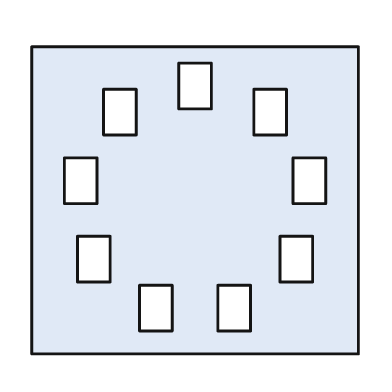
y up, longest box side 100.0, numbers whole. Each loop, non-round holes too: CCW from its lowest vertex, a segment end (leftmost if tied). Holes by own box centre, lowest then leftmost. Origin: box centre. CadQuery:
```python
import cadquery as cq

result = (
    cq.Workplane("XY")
    .moveTo(-50.0, -47.0)
    .lineTo(50.0, -47.0)
    .lineTo(50.0, 47.0)
    .lineTo(-50.0, 47.0)
    .close()
    .moveTo(-17.0, -40.0)
    .lineTo(-7.0, -40.0)
    .lineTo(-7.0, -26.0)
    .lineTo(-17.0, -26.0)
    .close()
    .moveTo(7.0, -40.0)
    .lineTo(17.0, -40.0)
    .lineTo(17.0, -26.0)
    .lineTo(7.0, -26.0)
    .close()
    .moveTo(-36.0, -25.0)
    .lineTo(-26.0, -25.0)
    .lineTo(-26.0, -11.0)
    .lineTo(-36.0, -11.0)
    .close()
    .moveTo(26.0, -25.0)
    .lineTo(36.0, -25.0)
    .lineTo(36.0, -11.0)
    .lineTo(26.0, -11.0)
    .close()
    .moveTo(-40.0, -1.0)
    .lineTo(-30.0, -1.0)
    .lineTo(-30.0, 13.0)
    .lineTo(-40.0, 13.0)
    .close()
    .moveTo(30.0, -1.0)
    .lineTo(40.0, -1.0)
    .lineTo(40.0, 13.0)
    .lineTo(30.0, 13.0)
    .close()
    .moveTo(-28.0, 20.0)
    .lineTo(-18.0, 20.0)
    .lineTo(-18.0, 34.0)
    .lineTo(-28.0, 34.0)
    .close()
    .moveTo(18.0, 20.0)
    .lineTo(28.0, 20.0)
    .lineTo(28.0, 34.0)
    .lineTo(18.0, 34.0)
    .close()
    .moveTo(-5.0, 28.0)
    .lineTo(5.0, 28.0)
    .lineTo(5.0, 42.0)
    .lineTo(-5.0, 42.0)
    .close()
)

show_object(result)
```